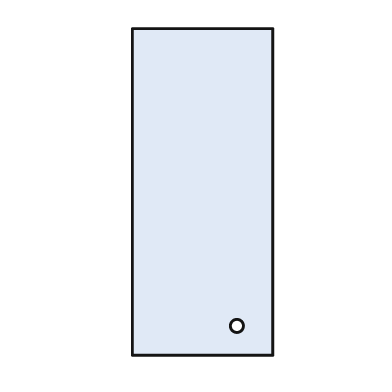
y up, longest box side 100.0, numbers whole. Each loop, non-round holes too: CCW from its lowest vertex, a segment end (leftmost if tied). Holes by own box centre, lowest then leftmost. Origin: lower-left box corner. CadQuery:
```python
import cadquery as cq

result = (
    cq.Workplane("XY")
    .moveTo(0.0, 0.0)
    .lineTo(43.0, 0.0)
    .lineTo(43.0, 100.0)
    .lineTo(0.0, 100.0)
    .close()
    .moveTo(32.0, 9.0)
    .circle(2.0)
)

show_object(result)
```